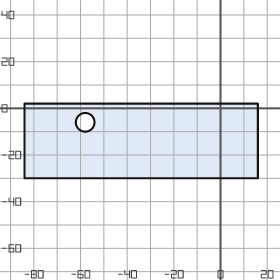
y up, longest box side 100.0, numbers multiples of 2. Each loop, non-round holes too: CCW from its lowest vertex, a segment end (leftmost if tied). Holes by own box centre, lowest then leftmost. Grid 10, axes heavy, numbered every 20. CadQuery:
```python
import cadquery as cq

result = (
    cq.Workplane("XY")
    .moveTo(-84.0, -30.0)
    .lineTo(16.0, -30.0)
    .lineTo(16.0, 2.0)
    .lineTo(-84.0, 2.0)
    .close()
    .moveTo(-58.0, -6.0)
    .circle(4.0)
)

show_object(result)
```